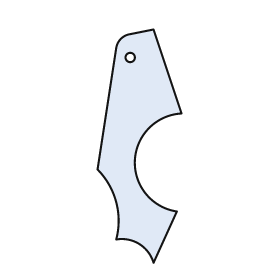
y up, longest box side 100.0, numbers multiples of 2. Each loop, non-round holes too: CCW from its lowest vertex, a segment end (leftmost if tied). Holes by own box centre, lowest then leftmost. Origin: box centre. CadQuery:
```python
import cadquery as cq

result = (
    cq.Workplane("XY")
    .moveTo(6.0, -50.0)
    .lineTo(16.0, -28.0)
    .threePointArc((-2.0, -6.0), (18.0, 14.0))
    .lineTo(6.0, 50.0)
    .lineTo(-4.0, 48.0)
    .threePointArc((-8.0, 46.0), (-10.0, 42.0))
    .lineTo(-18.0, -10.0)
    .threePointArc((-10.0, -24.0), (-10.0, -40.0))
    .threePointArc((0.0, -42.0), (6.0, -50.0))
    .close()
    .moveTo(-4.0, 38.0)
    .circle(2.0)
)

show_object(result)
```